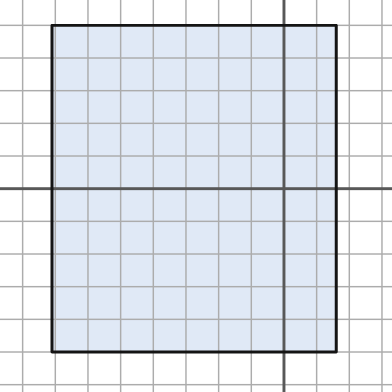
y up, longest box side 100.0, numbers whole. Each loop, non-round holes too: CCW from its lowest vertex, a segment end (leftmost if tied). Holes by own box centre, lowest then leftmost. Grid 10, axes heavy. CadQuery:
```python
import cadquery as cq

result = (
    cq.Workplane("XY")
    .moveTo(-71.0, -50.0)
    .lineTo(16.0, -50.0)
    .lineTo(16.0, 50.0)
    .lineTo(-71.0, 50.0)
    .close()
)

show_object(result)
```